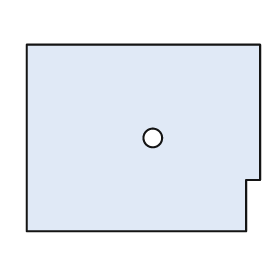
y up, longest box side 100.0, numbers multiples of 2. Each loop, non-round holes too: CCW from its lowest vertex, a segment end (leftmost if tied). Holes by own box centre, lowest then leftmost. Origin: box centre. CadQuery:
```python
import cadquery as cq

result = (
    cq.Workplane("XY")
    .moveTo(-50.0, -40.0)
    .lineTo(44.0, -40.0)
    .lineTo(44.0, -18.0)
    .lineTo(50.0, -18.0)
    .lineTo(50.0, 40.0)
    .lineTo(-50.0, 40.0)
    .close()
    .moveTo(4.0, 0.0)
    .circle(4.0)
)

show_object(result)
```